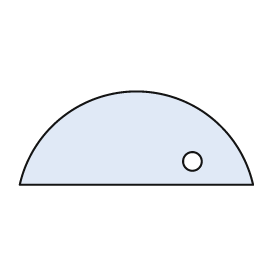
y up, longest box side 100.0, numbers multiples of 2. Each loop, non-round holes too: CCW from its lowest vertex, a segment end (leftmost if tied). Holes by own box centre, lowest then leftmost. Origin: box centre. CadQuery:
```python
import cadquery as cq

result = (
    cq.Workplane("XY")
    .moveTo(-50.0, -20.0)
    .lineTo(50.0, -20.0)
    .threePointArc((0.0, 20.0), (-50.0, -20.0))
    .close()
    .moveTo(24.0, -10.0)
    .circle(4.0)
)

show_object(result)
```